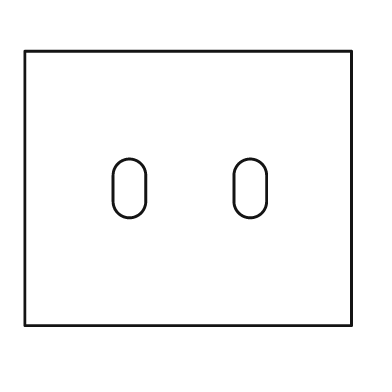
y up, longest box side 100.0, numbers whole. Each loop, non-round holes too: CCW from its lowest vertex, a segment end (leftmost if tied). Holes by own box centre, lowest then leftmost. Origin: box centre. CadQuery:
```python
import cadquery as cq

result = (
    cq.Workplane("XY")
    .moveTo(-50.0, -42.0)
    .lineTo(50.0, -42.0)
    .lineTo(50.0, 42.0)
    .lineTo(-50.0, 42.0)
    .close()
    .moveTo(-23.0, -4.0)
    .threePointArc((-18.0, -9.0), (-13.0, -4.0))
    .lineTo(-13.0, 4.0)
    .threePointArc((-18.0, 9.0), (-23.0, 4.0))
    .close()
    .moveTo(14.0, -4.0)
    .threePointArc((19.0, -9.0), (24.0, -4.0))
    .lineTo(24.0, 4.0)
    .threePointArc((19.0, 9.0), (14.0, 4.0))
    .close()
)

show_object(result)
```